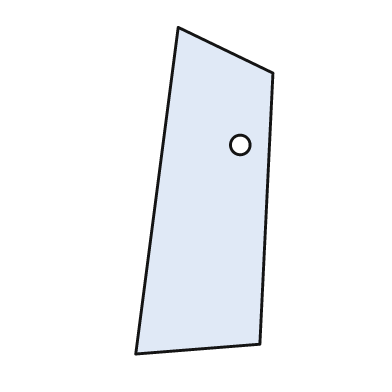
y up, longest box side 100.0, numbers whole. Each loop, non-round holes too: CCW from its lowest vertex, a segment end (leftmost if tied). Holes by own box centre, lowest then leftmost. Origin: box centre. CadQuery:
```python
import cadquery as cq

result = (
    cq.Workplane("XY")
    .moveTo(-21.0, -50.0)
    .lineTo(17.0, -47.0)
    .lineTo(21.0, 36.0)
    .lineTo(-8.0, 50.0)
    .close()
    .moveTo(11.0, 14.0)
    .circle(3.0)
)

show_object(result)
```